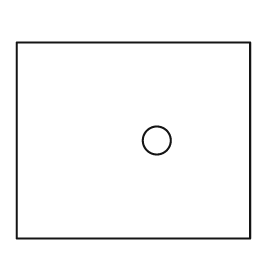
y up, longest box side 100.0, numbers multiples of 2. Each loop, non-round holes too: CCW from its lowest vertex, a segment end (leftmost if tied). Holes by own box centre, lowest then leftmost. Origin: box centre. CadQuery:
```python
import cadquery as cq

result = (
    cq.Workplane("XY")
    .moveTo(-50.0, -42.0)
    .lineTo(50.0, -42.0)
    .lineTo(50.0, 42.0)
    .lineTo(-50.0, 42.0)
    .close()
    .moveTo(10.0, 0.0)
    .circle(6.0)
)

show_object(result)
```